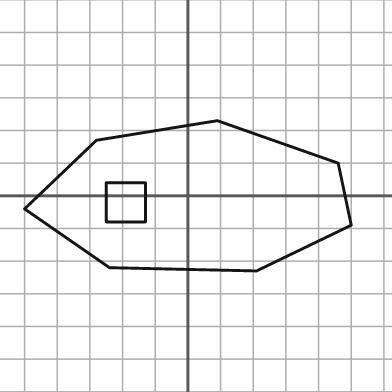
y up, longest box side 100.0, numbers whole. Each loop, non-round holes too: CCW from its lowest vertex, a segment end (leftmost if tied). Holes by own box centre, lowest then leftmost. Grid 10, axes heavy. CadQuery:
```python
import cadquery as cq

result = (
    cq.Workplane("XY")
    .moveTo(21.0, -23.0)
    .lineTo(50.0, -9.0)
    .lineTo(46.0, 10.0)
    .lineTo(9.0, 23.0)
    .lineTo(-28.0, 17.0)
    .lineTo(-50.0, -4.0)
    .lineTo(-24.0, -22.0)
    .close()
    .moveTo(-25.0, -8.0)
    .lineTo(-13.0, -8.0)
    .lineTo(-13.0, 4.0)
    .lineTo(-25.0, 4.0)
    .close()
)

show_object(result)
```